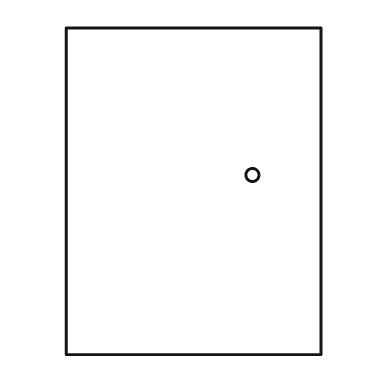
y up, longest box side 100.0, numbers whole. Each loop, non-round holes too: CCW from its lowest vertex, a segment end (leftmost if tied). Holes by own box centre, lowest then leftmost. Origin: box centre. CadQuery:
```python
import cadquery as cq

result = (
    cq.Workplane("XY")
    .moveTo(-39.0, -50.0)
    .lineTo(39.0, -50.0)
    .lineTo(39.0, 50.0)
    .lineTo(-39.0, 50.0)
    .close()
    .moveTo(18.0, 5.0)
    .circle(2.0)
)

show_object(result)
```